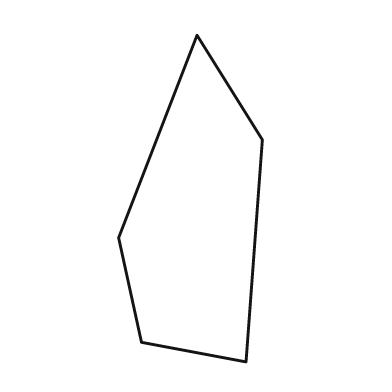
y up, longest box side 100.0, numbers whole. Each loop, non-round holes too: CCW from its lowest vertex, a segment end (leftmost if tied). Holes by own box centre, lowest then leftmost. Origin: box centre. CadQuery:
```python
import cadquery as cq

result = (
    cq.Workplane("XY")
    .moveTo(17.0, -50.0)
    .lineTo(22.0, 18.0)
    .lineTo(2.0, 50.0)
    .lineTo(-22.0, -12.0)
    .lineTo(-15.0, -44.0)
    .close()
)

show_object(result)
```